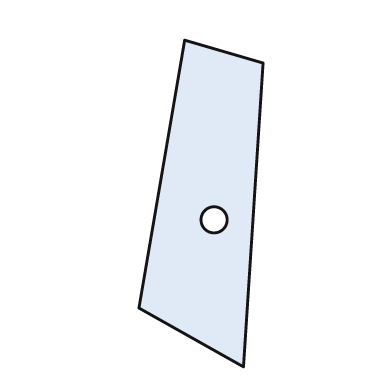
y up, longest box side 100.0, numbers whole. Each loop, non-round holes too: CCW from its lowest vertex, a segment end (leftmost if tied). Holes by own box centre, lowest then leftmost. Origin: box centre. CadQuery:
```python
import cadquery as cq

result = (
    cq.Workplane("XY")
    .moveTo(13.0, -50.0)
    .lineTo(19.0, 43.0)
    .lineTo(-5.0, 50.0)
    .lineTo(-19.0, -32.0)
    .close()
    .moveTo(4.0, -5.0)
    .circle(4.0)
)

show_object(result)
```